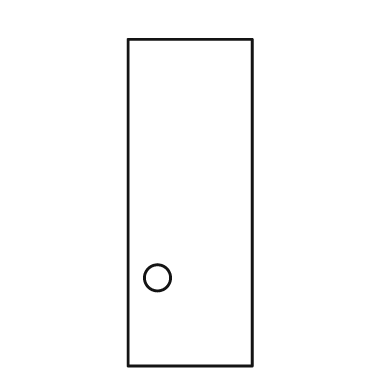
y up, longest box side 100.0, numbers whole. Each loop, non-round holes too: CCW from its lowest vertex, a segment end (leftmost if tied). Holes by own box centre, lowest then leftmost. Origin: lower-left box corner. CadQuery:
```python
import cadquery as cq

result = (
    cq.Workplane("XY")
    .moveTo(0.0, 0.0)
    .lineTo(38.0, 0.0)
    .lineTo(38.0, 100.0)
    .lineTo(0.0, 100.0)
    .close()
    .moveTo(9.0, 27.0)
    .circle(4.0)
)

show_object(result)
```